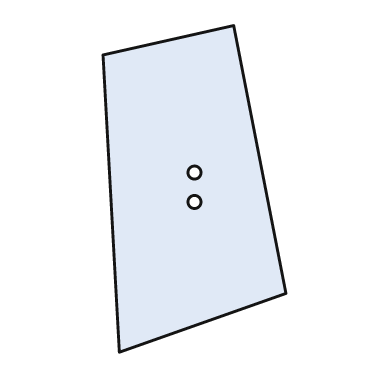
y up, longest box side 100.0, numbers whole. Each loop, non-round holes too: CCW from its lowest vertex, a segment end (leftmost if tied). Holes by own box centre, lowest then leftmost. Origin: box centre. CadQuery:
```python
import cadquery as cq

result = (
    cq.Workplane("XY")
    .moveTo(-23.0, -50.0)
    .lineTo(28.0, -32.0)
    .lineTo(12.0, 50.0)
    .lineTo(-28.0, 41.0)
    .close()
    .moveTo(0.0, -4.0)
    .circle(2.0)
    .moveTo(0.0, 5.0)
    .circle(2.0)
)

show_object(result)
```